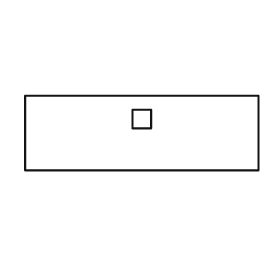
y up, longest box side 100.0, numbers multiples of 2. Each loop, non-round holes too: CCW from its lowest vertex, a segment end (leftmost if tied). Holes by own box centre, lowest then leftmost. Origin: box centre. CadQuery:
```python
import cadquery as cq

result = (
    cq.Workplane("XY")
    .moveTo(-50.0, -16.0)
    .lineTo(50.0, -16.0)
    .lineTo(50.0, 16.0)
    .lineTo(-50.0, 16.0)
    .close()
    .moveTo(-4.0, 2.0)
    .lineTo(4.0, 2.0)
    .lineTo(4.0, 10.0)
    .lineTo(-4.0, 10.0)
    .close()
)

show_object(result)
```